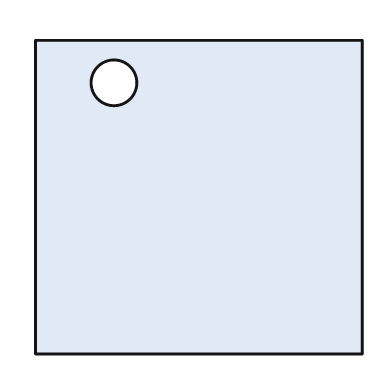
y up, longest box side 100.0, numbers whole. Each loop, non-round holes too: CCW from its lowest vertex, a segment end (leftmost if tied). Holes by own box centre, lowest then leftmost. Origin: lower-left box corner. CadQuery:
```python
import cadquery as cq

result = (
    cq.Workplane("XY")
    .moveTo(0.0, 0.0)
    .lineTo(100.0, 0.0)
    .lineTo(100.0, 96.0)
    .lineTo(0.0, 96.0)
    .close()
    .moveTo(24.0, 83.0)
    .circle(7.0)
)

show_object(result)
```